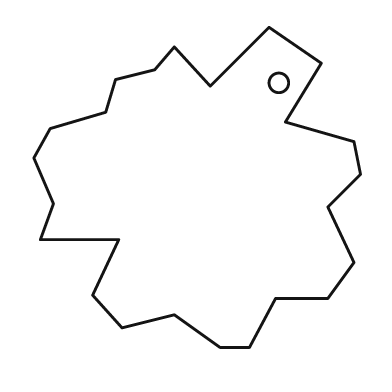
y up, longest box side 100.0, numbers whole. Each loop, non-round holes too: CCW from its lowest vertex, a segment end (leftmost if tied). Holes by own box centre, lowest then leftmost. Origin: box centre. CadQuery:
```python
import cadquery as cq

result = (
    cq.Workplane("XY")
    .moveTo(7.0, -49.0)
    .lineTo(16.0, -49.0)
    .lineTo(24.0, -34.0)
    .lineTo(40.0, -34.0)
    .lineTo(48.0, -23.0)
    .lineTo(40.0, -6.0)
    .lineTo(50.0, 4.0)
    .lineTo(48.0, 14.0)
    .lineTo(27.0, 20.0)
    .lineTo(38.0, 38.0)
    .lineTo(22.0, 49.0)
    .lineTo(4.0, 31.0)
    .lineTo(-7.0, 43.0)
    .lineTo(-13.0, 36.0)
    .lineTo(-25.0, 33.0)
    .lineTo(-28.0, 23.0)
    .lineTo(-45.0, 18.0)
    .lineTo(-50.0, 9.0)
    .lineTo(-44.0, -5.0)
    .lineTo(-48.0, -16.0)
    .lineTo(-24.0, -16.0)
    .lineTo(-32.0, -33.0)
    .lineTo(-23.0, -43.0)
    .lineTo(-7.0, -39.0)
    .close()
    .moveTo(25.0, 32.0)
    .circle(3.0)
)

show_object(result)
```